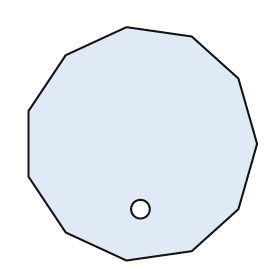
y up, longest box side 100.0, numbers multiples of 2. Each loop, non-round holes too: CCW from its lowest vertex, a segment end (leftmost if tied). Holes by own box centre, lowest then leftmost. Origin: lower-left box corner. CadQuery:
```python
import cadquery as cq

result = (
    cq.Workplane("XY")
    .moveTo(42.0, 0.0)
    .lineTo(70.0, 4.0)
    .lineTo(90.0, 22.0)
    .lineTo(98.0, 50.0)
    .lineTo(90.0, 78.0)
    .lineTo(70.0, 96.0)
    .lineTo(42.0, 100.0)
    .lineTo(16.0, 88.0)
    .lineTo(0.0, 64.0)
    .lineTo(0.0, 36.0)
    .lineTo(16.0, 12.0)
    .close()
    .moveTo(48.0, 22.0)
    .circle(4.0)
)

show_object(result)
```